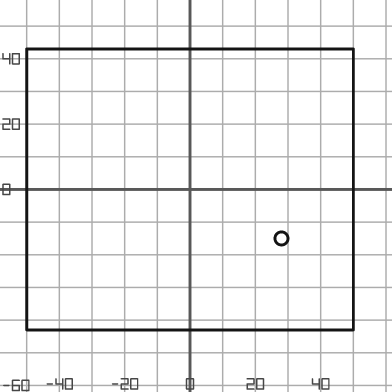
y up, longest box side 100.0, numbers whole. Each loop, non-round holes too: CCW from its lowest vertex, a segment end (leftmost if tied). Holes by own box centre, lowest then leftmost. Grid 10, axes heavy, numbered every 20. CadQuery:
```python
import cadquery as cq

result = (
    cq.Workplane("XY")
    .moveTo(-50.0, -43.0)
    .lineTo(50.0, -43.0)
    .lineTo(50.0, 43.0)
    .lineTo(-50.0, 43.0)
    .close()
    .moveTo(28.0, -15.0)
    .circle(2.0)
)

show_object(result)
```